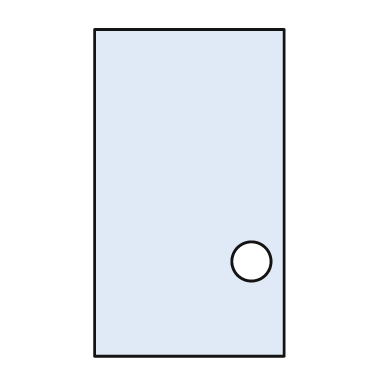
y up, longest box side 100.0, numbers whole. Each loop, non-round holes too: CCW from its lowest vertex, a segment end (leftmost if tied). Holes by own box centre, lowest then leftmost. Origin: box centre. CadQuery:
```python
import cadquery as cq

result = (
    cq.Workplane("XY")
    .moveTo(-29.0, -50.0)
    .lineTo(29.0, -50.0)
    .lineTo(29.0, 50.0)
    .lineTo(-29.0, 50.0)
    .close()
    .moveTo(19.0, -21.0)
    .circle(6.0)
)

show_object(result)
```